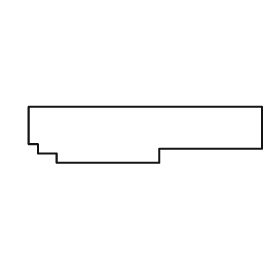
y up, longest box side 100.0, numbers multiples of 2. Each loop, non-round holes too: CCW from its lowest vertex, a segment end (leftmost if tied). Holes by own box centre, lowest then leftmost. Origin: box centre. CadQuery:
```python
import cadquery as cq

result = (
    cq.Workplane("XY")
    .moveTo(-38.0, -12.0)
    .lineTo(6.0, -12.0)
    .lineTo(6.0, -6.0)
    .lineTo(50.0, -6.0)
    .lineTo(50.0, 12.0)
    .lineTo(-50.0, 12.0)
    .lineTo(-50.0, -4.0)
    .lineTo(-46.0, -4.0)
    .lineTo(-46.0, -8.0)
    .lineTo(-38.0, -8.0)
    .close()
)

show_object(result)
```